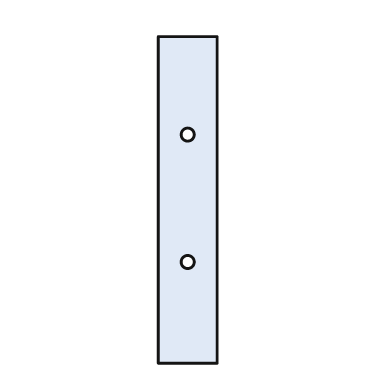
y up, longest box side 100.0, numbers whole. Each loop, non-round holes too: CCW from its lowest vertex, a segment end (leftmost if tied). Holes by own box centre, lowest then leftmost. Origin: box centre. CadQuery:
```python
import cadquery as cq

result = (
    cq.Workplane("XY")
    .moveTo(-9.0, -50.0)
    .lineTo(9.0, -50.0)
    .lineTo(9.0, 50.0)
    .lineTo(-9.0, 50.0)
    .close()
    .moveTo(0.0, -19.0)
    .circle(2.0)
    .moveTo(0.0, 20.0)
    .circle(2.0)
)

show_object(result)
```